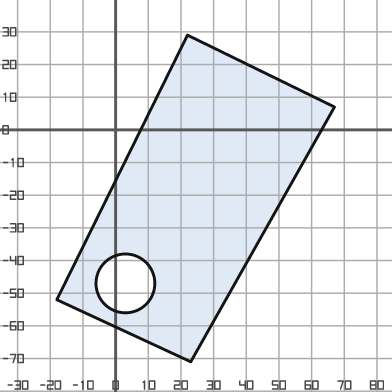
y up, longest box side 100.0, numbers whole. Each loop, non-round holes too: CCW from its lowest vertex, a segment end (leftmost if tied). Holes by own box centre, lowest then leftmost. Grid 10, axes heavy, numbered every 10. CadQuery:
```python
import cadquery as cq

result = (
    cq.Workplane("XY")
    .moveTo(23.0, -71.0)
    .lineTo(67.0, 7.0)
    .lineTo(22.0, 29.0)
    .lineTo(-18.0, -52.0)
    .close()
    .moveTo(3.0, -47.0)
    .circle(9.0)
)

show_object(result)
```